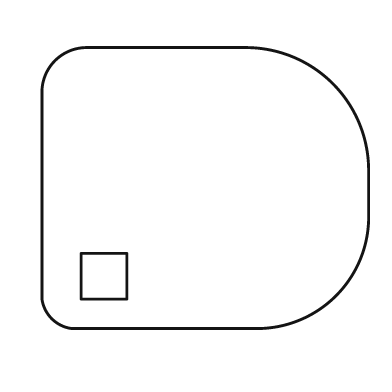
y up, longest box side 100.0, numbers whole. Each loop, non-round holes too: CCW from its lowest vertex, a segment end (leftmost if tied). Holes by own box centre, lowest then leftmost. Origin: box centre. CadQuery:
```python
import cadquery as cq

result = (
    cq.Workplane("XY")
    .moveTo(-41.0, -43.0)
    .lineTo(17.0, -43.0)
    .threePointArc((40.0, -33.0), (50.0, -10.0))
    .lineTo(50.0, 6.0)
    .threePointArc((39.0, 32.0), (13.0, 43.0))
    .lineTo(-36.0, 43.0)
    .threePointArc((-46.0, 39.0), (-50.0, 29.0))
    .lineTo(-50.0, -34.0)
    .threePointArc((-47.0, -40.0), (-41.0, -43.0))
    .close()
    .moveTo(-38.0, -34.0)
    .lineTo(-24.0, -34.0)
    .lineTo(-24.0, -20.0)
    .lineTo(-38.0, -20.0)
    .close()
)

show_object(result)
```